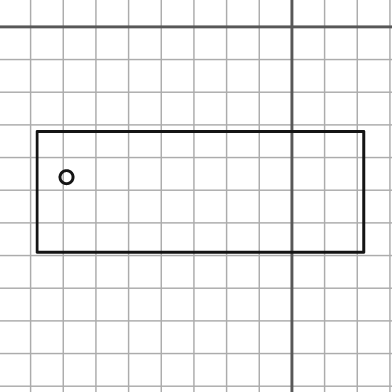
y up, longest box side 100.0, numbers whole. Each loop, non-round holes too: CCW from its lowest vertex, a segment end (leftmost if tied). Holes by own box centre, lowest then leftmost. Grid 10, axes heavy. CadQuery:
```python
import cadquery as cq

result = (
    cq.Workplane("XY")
    .moveTo(-78.0, -69.0)
    .lineTo(22.0, -69.0)
    .lineTo(22.0, -32.0)
    .lineTo(-78.0, -32.0)
    .close()
    .moveTo(-69.0, -46.0)
    .circle(2.0)
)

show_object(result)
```